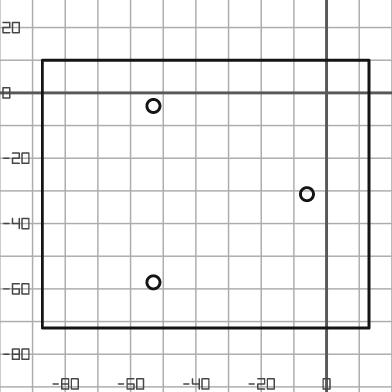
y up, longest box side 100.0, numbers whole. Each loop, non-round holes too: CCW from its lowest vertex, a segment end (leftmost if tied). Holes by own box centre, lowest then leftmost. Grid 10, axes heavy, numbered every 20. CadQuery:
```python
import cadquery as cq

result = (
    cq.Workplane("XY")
    .moveTo(-87.0, -72.0)
    .lineTo(13.0, -72.0)
    .lineTo(13.0, 10.0)
    .lineTo(-87.0, 10.0)
    .close()
    .moveTo(-53.0, -58.0)
    .circle(2.0)
    .moveTo(-6.0, -31.0)
    .circle(2.0)
    .moveTo(-53.0, -4.0)
    .circle(2.0)
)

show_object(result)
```